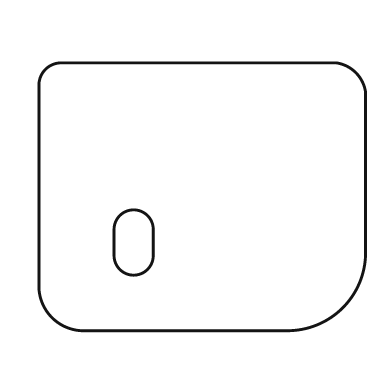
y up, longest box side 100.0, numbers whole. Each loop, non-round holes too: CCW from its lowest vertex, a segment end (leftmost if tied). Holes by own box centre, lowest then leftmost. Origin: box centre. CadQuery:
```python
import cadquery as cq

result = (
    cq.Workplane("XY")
    .moveTo(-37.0, -41.0)
    .lineTo(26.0, -41.0)
    .threePointArc((43.0, -34.0), (50.0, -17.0))
    .lineTo(50.0, 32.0)
    .threePointArc((47.0, 38.0), (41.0, 41.0))
    .lineTo(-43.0, 41.0)
    .threePointArc((-48.0, 39.0), (-50.0, 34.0))
    .lineTo(-50.0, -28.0)
    .threePointArc((-46.0, -37.0), (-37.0, -41.0))
    .close()
    .moveTo(-27.0, -18.0)
    .threePointArc((-21.0, -24.0), (-15.0, -18.0))
    .lineTo(-15.0, -10.0)
    .threePointArc((-21.0, -4.0), (-27.0, -10.0))
    .close()
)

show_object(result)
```